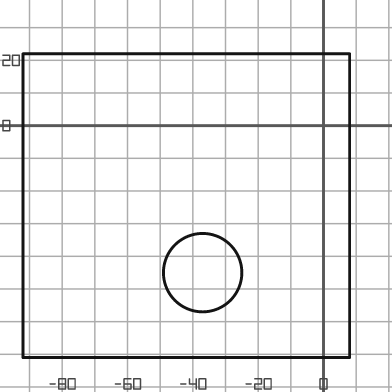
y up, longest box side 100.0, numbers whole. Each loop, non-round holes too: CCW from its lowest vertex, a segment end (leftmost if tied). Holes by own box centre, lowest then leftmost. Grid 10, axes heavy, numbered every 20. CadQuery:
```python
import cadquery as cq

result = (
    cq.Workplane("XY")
    .moveTo(-92.0, -71.0)
    .lineTo(8.0, -71.0)
    .lineTo(8.0, 22.0)
    .lineTo(-92.0, 22.0)
    .close()
    .moveTo(-37.0, -45.0)
    .circle(12.0)
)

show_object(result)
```